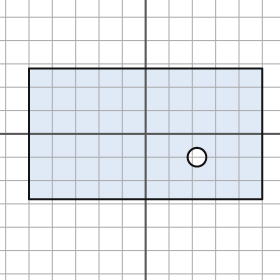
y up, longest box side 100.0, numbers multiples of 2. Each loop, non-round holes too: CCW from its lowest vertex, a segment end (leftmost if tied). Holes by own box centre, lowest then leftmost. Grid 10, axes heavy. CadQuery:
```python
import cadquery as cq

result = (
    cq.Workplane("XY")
    .moveTo(-50.0, -28.0)
    .lineTo(50.0, -28.0)
    .lineTo(50.0, 28.0)
    .lineTo(-50.0, 28.0)
    .close()
    .moveTo(22.0, -10.0)
    .circle(4.0)
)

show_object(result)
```